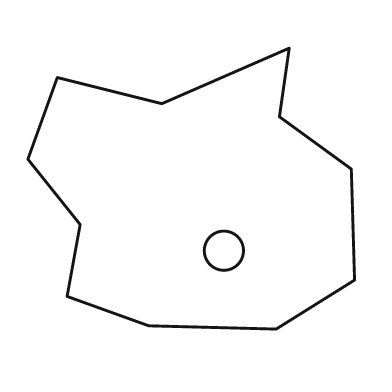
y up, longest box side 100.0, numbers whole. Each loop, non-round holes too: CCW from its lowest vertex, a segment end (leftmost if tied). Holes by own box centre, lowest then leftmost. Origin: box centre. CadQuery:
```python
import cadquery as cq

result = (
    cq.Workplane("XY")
    .moveTo(26.0, -43.0)
    .lineTo(50.0, -28.0)
    .lineTo(49.0, 6.0)
    .lineTo(27.0, 22.0)
    .lineTo(30.0, 43.0)
    .lineTo(-9.0, 26.0)
    .lineTo(-41.0, 34.0)
    .lineTo(-50.0, 9.0)
    .lineTo(-34.0, -11.0)
    .lineTo(-38.0, -33.0)
    .lineTo(-13.0, -42.0)
    .close()
    .moveTo(10.0, -19.0)
    .circle(6.0)
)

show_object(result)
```